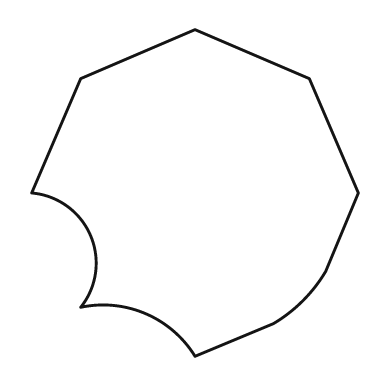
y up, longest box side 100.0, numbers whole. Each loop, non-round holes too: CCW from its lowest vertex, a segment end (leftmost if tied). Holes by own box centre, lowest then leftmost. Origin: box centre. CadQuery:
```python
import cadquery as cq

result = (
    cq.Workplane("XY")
    .moveTo(0.0, -50.0)
    .lineTo(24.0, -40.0)
    .threePointArc((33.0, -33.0), (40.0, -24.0))
    .lineTo(50.0, 0.0)
    .lineTo(35.0, 35.0)
    .lineTo(0.0, 50.0)
    .lineTo(-35.0, 35.0)
    .lineTo(-50.0, 0.0)
    .threePointArc((-32.0, -13.0), (-35.0, -35.0))
    .threePointArc((-15.0, -37.0), (0.0, -50.0))
    .close()
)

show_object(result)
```